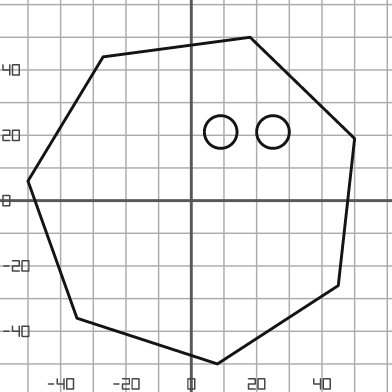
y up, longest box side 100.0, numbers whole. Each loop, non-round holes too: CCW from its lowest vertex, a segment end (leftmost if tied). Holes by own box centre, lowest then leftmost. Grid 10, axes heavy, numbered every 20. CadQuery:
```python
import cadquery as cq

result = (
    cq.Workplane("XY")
    .moveTo(8.0, -50.0)
    .lineTo(45.0, -26.0)
    .lineTo(50.0, 19.0)
    .lineTo(18.0, 50.0)
    .lineTo(-27.0, 44.0)
    .lineTo(-50.0, 6.0)
    .lineTo(-35.0, -36.0)
    .close()
    .moveTo(9.0, 21.0)
    .circle(5.0)
    .moveTo(25.0, 21.0)
    .circle(5.0)
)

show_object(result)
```